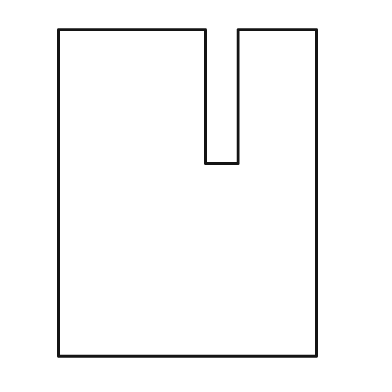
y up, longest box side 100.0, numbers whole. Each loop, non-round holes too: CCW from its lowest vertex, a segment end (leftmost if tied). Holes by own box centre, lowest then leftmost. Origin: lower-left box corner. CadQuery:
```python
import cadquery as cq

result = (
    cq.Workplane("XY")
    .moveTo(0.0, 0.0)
    .lineTo(79.0, 0.0)
    .lineTo(79.0, 100.0)
    .lineTo(55.0, 100.0)
    .lineTo(55.0, 59.0)
    .lineTo(45.0, 59.0)
    .lineTo(45.0, 100.0)
    .lineTo(0.0, 100.0)
    .close()
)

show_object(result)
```